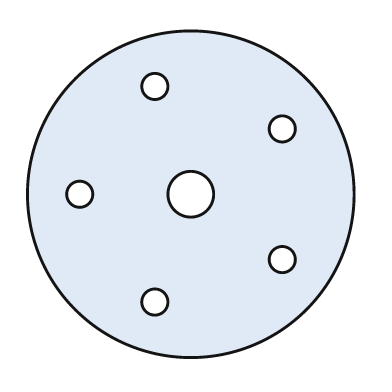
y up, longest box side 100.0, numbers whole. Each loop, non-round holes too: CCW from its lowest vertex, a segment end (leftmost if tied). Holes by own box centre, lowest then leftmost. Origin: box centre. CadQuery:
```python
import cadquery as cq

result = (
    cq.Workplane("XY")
    .moveTo(0.0, 0.0)
    .circle(50.0)
    .moveTo(-11.0, -33.0)
    .circle(4.0)
    .moveTo(28.0, -20.0)
    .circle(4.0)
    .moveTo(-34.0, 0.0)
    .circle(4.0)
    .moveTo(0.0, 0.0)
    .circle(7.0)
    .moveTo(28.0, 20.0)
    .circle(4.0)
    .moveTo(-11.0, 33.0)
    .circle(4.0)
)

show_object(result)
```